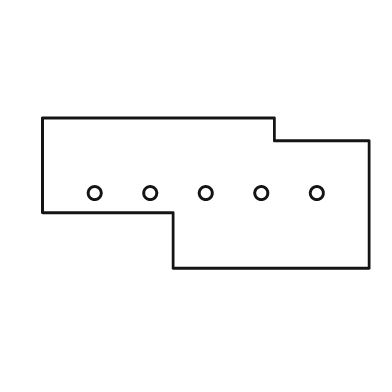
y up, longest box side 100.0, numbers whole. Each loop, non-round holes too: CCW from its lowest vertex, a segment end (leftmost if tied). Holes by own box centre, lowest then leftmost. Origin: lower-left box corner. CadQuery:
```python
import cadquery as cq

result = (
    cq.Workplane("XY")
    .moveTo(40.0, 0.0)
    .lineTo(100.0, 0.0)
    .lineTo(100.0, 39.0)
    .lineTo(71.0, 39.0)
    .lineTo(71.0, 46.0)
    .lineTo(0.0, 46.0)
    .lineTo(0.0, 17.0)
    .lineTo(40.0, 17.0)
    .close()
    .moveTo(16.0, 23.0)
    .circle(2.0)
    .moveTo(33.0, 23.0)
    .circle(2.0)
    .moveTo(50.0, 23.0)
    .circle(2.0)
    .moveTo(67.0, 23.0)
    .circle(2.0)
    .moveTo(84.0, 23.0)
    .circle(2.0)
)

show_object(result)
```